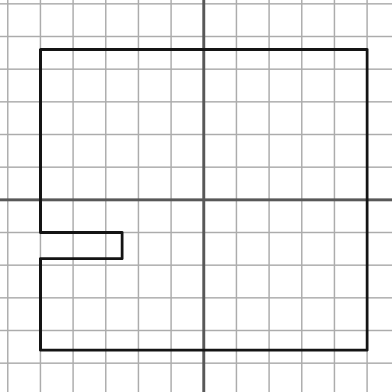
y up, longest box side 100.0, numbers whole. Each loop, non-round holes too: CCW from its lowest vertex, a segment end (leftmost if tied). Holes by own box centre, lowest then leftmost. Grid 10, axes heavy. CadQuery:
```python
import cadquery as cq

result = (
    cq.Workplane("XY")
    .moveTo(-50.0, -46.0)
    .lineTo(50.0, -46.0)
    .lineTo(50.0, 46.0)
    .lineTo(-50.0, 46.0)
    .lineTo(-50.0, -10.0)
    .lineTo(-25.0, -10.0)
    .lineTo(-25.0, -18.0)
    .lineTo(-50.0, -18.0)
    .close()
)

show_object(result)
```